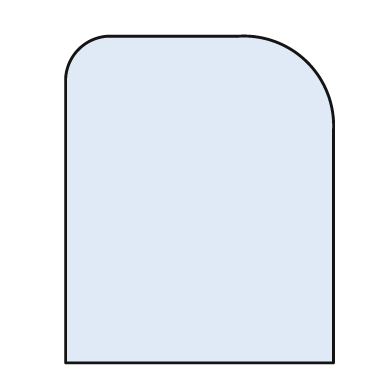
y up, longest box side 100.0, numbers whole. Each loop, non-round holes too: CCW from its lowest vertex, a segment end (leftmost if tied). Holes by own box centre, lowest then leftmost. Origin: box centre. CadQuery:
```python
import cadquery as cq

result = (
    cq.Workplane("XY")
    .moveTo(-41.0, -50.0)
    .lineTo(41.0, -50.0)
    .lineTo(41.0, 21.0)
    .threePointArc((33.0, 42.0), (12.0, 50.0))
    .lineTo(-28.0, 50.0)
    .threePointArc((-37.0, 46.0), (-41.0, 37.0))
    .close()
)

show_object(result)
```